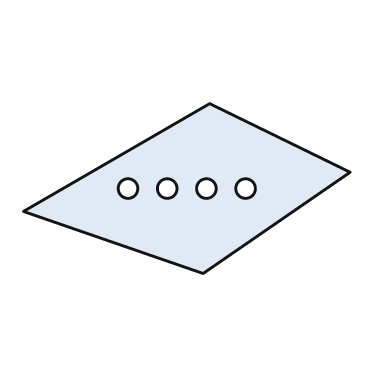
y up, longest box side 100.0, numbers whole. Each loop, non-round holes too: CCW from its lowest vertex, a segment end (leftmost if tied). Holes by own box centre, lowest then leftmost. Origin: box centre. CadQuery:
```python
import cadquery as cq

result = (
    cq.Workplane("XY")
    .moveTo(5.0, -26.0)
    .lineTo(50.0, 5.0)
    .lineTo(7.0, 26.0)
    .lineTo(-50.0, -7.0)
    .close()
    .moveTo(-18.0, 0.0)
    .circle(3.0)
    .moveTo(-6.0, 0.0)
    .circle(3.0)
    .moveTo(6.0, 0.0)
    .circle(3.0)
    .moveTo(18.0, 0.0)
    .circle(3.0)
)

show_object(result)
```